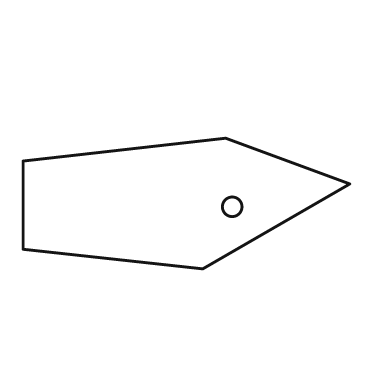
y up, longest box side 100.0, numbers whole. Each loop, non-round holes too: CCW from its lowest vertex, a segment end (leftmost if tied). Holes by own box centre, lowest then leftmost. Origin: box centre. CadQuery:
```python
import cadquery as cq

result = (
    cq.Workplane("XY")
    .moveTo(5.0, -20.0)
    .lineTo(50.0, 6.0)
    .lineTo(12.0, 20.0)
    .lineTo(-50.0, 13.0)
    .lineTo(-50.0, -14.0)
    .close()
    .moveTo(14.0, -1.0)
    .circle(3.0)
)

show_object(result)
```